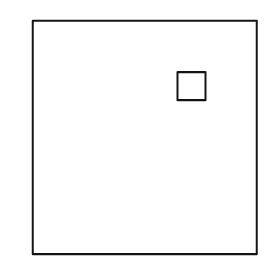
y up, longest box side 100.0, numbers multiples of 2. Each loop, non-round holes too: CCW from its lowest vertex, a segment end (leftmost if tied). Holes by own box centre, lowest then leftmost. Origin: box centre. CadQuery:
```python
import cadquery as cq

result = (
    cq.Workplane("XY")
    .moveTo(-48.0, -50.0)
    .lineTo(48.0, -50.0)
    .lineTo(48.0, 50.0)
    .lineTo(-48.0, 50.0)
    .close()
    .moveTo(14.0, 16.0)
    .lineTo(26.0, 16.0)
    .lineTo(26.0, 28.0)
    .lineTo(14.0, 28.0)
    .close()
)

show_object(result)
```